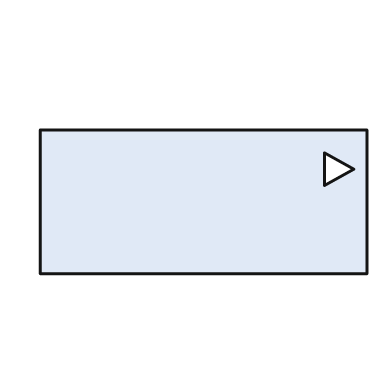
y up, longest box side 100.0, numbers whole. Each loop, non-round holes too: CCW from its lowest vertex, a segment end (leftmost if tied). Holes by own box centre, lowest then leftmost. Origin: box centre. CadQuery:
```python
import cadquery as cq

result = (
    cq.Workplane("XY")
    .moveTo(-50.0, -22.0)
    .lineTo(50.0, -22.0)
    .lineTo(50.0, 22.0)
    .lineTo(-50.0, 22.0)
    .close()
    .moveTo(37.0, 5.0)
    .lineTo(46.0, 10.0)
    .lineTo(37.0, 15.0)
    .close()
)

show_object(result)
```